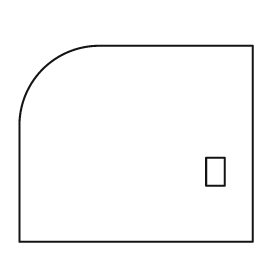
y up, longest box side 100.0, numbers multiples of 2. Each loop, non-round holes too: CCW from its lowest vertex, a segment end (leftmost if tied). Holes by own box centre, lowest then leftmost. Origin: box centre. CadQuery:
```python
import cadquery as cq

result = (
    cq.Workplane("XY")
    .moveTo(-50.0, -42.0)
    .lineTo(50.0, -42.0)
    .lineTo(50.0, 42.0)
    .lineTo(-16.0, 42.0)
    .threePointArc((-40.0, 32.0), (-50.0, 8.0))
    .close()
    .moveTo(30.0, -18.0)
    .lineTo(38.0, -18.0)
    .lineTo(38.0, -6.0)
    .lineTo(30.0, -6.0)
    .close()
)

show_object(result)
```